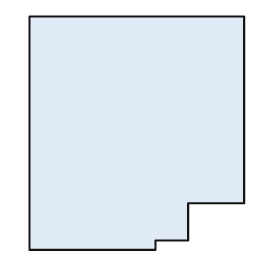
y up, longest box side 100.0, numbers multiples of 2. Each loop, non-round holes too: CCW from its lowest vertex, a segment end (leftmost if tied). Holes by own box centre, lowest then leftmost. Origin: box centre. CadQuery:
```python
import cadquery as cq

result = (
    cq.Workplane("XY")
    .moveTo(-46.0, -50.0)
    .lineTo(8.0, -50.0)
    .lineTo(8.0, -46.0)
    .lineTo(22.0, -46.0)
    .lineTo(22.0, -30.0)
    .lineTo(46.0, -30.0)
    .lineTo(46.0, 50.0)
    .lineTo(-46.0, 50.0)
    .close()
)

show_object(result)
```